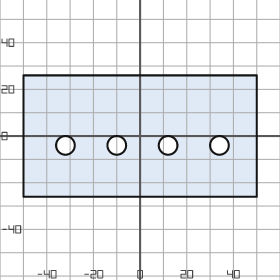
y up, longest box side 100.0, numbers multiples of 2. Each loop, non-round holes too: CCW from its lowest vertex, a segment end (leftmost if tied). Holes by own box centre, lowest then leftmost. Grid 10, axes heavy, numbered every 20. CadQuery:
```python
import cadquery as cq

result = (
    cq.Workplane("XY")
    .moveTo(-50.0, -26.0)
    .lineTo(50.0, -26.0)
    .lineTo(50.0, 26.0)
    .lineTo(-50.0, 26.0)
    .close()
    .moveTo(-32.0, -4.0)
    .circle(4.0)
    .moveTo(-10.0, -4.0)
    .circle(4.0)
    .moveTo(12.0, -4.0)
    .circle(4.0)
    .moveTo(34.0, -4.0)
    .circle(4.0)
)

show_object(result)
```